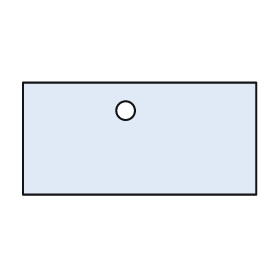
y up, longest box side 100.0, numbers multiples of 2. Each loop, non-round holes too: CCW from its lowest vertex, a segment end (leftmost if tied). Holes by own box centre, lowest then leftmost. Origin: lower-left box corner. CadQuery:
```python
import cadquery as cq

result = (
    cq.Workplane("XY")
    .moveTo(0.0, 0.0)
    .lineTo(100.0, 0.0)
    .lineTo(100.0, 48.0)
    .lineTo(0.0, 48.0)
    .close()
    .moveTo(44.0, 36.0)
    .circle(4.0)
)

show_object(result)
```